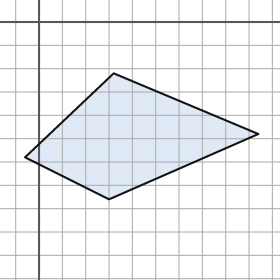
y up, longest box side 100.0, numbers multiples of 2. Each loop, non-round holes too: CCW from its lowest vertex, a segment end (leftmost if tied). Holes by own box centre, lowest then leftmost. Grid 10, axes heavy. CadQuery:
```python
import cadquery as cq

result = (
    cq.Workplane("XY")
    .moveTo(30.0, -76.0)
    .lineTo(94.0, -48.0)
    .lineTo(32.0, -22.0)
    .lineTo(-6.0, -58.0)
    .close()
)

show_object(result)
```